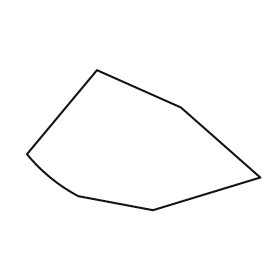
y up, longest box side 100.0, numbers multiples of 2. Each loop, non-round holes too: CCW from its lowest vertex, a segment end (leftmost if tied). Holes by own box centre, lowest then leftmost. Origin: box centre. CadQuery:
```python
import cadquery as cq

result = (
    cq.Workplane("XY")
    .moveTo(4.0, -30.0)
    .lineTo(50.0, -16.0)
    .lineTo(16.0, 14.0)
    .lineTo(-20.0, 30.0)
    .lineTo(-50.0, -6.0)
    .threePointArc((-40.0, -16.0), (-28.0, -24.0))
    .close()
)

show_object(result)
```